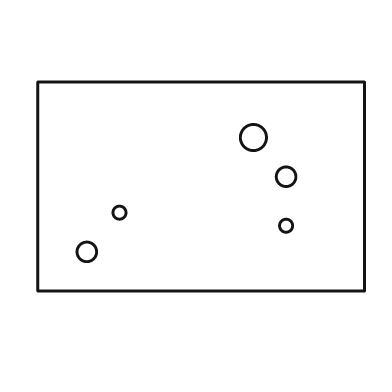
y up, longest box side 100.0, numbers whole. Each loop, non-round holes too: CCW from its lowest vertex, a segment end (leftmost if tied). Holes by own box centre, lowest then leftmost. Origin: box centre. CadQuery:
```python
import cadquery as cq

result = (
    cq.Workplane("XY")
    .moveTo(-50.0, -32.0)
    .lineTo(50.0, -32.0)
    .lineTo(50.0, 32.0)
    .lineTo(-50.0, 32.0)
    .close()
    .moveTo(-35.0, -20.0)
    .circle(3.0)
    .moveTo(26.0, -12.0)
    .circle(2.0)
    .moveTo(-25.0, -8.0)
    .circle(2.0)
    .moveTo(26.0, 3.0)
    .circle(3.0)
    .moveTo(16.0, 15.0)
    .circle(4.0)
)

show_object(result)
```